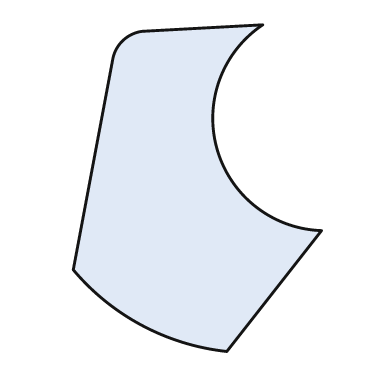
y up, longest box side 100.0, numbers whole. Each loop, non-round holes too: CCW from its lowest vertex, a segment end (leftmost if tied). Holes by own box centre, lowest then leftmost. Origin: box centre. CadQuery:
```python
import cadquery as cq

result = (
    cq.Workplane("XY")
    .moveTo(9.0, -50.0)
    .lineTo(38.0, -13.0)
    .threePointArc((6.0, 12.0), (20.0, 50.0))
    .lineTo(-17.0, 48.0)
    .threePointArc((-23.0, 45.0), (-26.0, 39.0))
    .lineTo(-38.0, -25.0)
    .threePointArc((-17.0, -42.0), (9.0, -50.0))
    .close()
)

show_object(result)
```